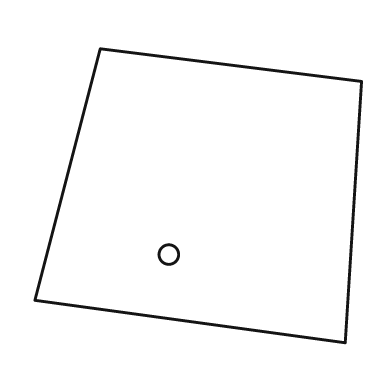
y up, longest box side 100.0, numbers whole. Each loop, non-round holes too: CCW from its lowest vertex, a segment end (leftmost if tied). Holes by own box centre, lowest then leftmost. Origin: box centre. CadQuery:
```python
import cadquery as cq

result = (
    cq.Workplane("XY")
    .moveTo(45.0, -45.0)
    .lineTo(50.0, 35.0)
    .lineTo(-30.0, 45.0)
    .lineTo(-50.0, -32.0)
    .close()
    .moveTo(-9.0, -18.0)
    .circle(3.0)
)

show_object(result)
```